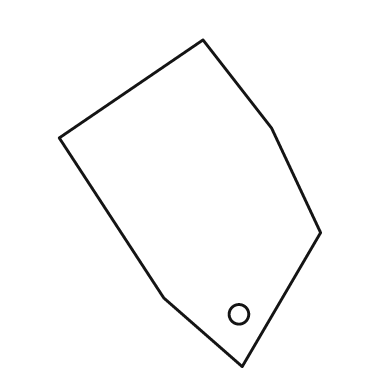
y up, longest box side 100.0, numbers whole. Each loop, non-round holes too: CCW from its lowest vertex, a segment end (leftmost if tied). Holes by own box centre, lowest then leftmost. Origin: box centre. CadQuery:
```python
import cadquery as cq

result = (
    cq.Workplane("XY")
    .moveTo(16.0, -50.0)
    .lineTo(40.0, -9.0)
    .lineTo(25.0, 23.0)
    .lineTo(4.0, 50.0)
    .lineTo(-40.0, 20.0)
    .lineTo(-8.0, -29.0)
    .close()
    .moveTo(15.0, -34.0)
    .circle(3.0)
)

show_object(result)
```